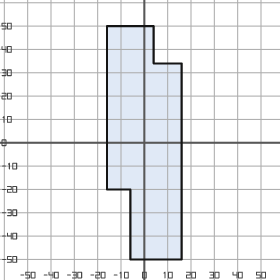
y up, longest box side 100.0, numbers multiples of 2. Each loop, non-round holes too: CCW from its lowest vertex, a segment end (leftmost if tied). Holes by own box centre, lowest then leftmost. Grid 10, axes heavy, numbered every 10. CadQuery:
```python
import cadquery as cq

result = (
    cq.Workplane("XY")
    .moveTo(-6.0, -50.0)
    .lineTo(16.0, -50.0)
    .lineTo(16.0, 34.0)
    .lineTo(4.0, 34.0)
    .lineTo(4.0, 50.0)
    .lineTo(-16.0, 50.0)
    .lineTo(-16.0, -20.0)
    .lineTo(-6.0, -20.0)
    .close()
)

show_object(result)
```